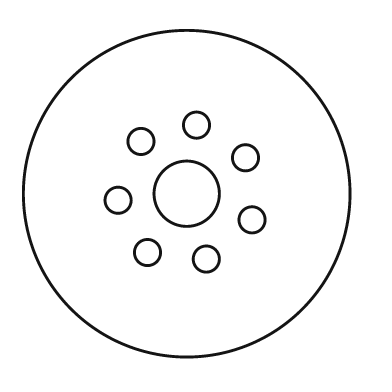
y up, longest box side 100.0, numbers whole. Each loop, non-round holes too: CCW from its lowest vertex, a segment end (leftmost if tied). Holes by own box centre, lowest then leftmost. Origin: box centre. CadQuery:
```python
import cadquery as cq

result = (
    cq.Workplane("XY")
    .moveTo(0.0, 0.0)
    .circle(50.0)
    .moveTo(6.0, -20.0)
    .circle(4.0)
    .moveTo(-12.0, -18.0)
    .circle(4.0)
    .moveTo(20.0, -8.0)
    .circle(4.0)
    .moveTo(-21.0, -2.0)
    .circle(4.0)
    .moveTo(0.0, 0.0)
    .circle(10.0)
    .moveTo(18.0, 11.0)
    .circle(4.0)
    .moveTo(-14.0, 16.0)
    .circle(4.0)
    .moveTo(3.0, 21.0)
    .circle(4.0)
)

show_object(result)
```